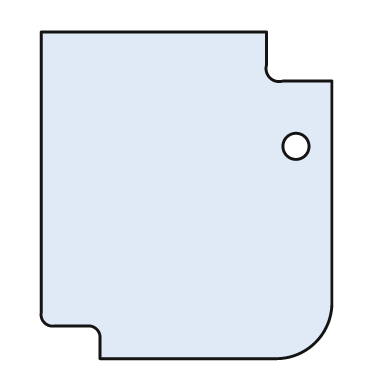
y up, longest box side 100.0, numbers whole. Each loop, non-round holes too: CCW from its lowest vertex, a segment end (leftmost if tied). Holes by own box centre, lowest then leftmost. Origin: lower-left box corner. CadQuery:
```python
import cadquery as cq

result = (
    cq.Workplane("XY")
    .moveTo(18.0, 0.0)
    .lineTo(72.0, 0.0)
    .threePointArc((84.0, 5.0), (89.0, 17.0))
    .lineTo(89.0, 85.0)
    .lineTo(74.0, 85.0)
    .threePointArc((70.0, 86.0), (69.0, 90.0))
    .lineTo(69.0, 100.0)
    .lineTo(0.0, 100.0)
    .lineTo(0.0, 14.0)
    .threePointArc((1.0, 11.0), (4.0, 10.0))
    .lineTo(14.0, 10.0)
    .threePointArc((17.0, 9.0), (18.0, 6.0))
    .close()
    .moveTo(78.0, 65.0)
    .circle(4.0)
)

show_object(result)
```